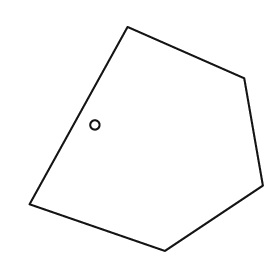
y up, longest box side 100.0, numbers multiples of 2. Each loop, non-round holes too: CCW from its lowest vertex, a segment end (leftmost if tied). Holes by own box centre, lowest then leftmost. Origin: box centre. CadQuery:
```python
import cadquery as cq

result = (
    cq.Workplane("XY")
    .moveTo(8.0, -48.0)
    .lineTo(50.0, -20.0)
    .lineTo(42.0, 26.0)
    .lineTo(-8.0, 48.0)
    .lineTo(-50.0, -28.0)
    .close()
    .moveTo(-22.0, 6.0)
    .circle(2.0)
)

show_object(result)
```